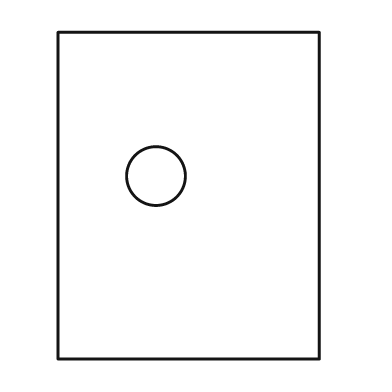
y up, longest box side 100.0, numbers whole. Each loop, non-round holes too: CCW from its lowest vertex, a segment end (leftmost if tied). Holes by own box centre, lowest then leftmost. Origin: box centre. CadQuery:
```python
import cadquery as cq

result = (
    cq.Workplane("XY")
    .moveTo(-40.0, -50.0)
    .lineTo(40.0, -50.0)
    .lineTo(40.0, 50.0)
    .lineTo(-40.0, 50.0)
    .close()
    .moveTo(-10.0, 6.0)
    .circle(9.0)
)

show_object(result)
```